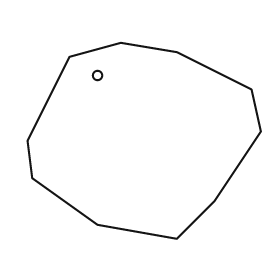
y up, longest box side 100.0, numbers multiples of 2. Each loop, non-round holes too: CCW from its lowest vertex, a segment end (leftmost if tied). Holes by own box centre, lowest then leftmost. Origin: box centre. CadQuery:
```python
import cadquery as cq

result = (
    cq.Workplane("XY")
    .moveTo(14.0, -42.0)
    .lineTo(30.0, -26.0)
    .lineTo(50.0, 4.0)
    .lineTo(46.0, 22.0)
    .lineTo(14.0, 38.0)
    .lineTo(-10.0, 42.0)
    .lineTo(-32.0, 36.0)
    .lineTo(-50.0, 0.0)
    .lineTo(-48.0, -16.0)
    .lineTo(-20.0, -36.0)
    .close()
    .moveTo(-20.0, 28.0)
    .circle(2.0)
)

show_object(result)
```